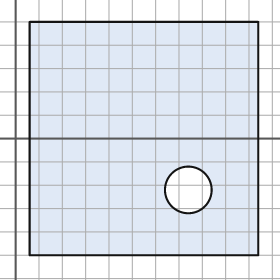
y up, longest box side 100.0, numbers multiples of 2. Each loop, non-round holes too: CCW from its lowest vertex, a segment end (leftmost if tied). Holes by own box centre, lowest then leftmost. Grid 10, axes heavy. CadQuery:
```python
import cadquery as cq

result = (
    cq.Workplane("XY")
    .moveTo(6.0, -50.0)
    .lineTo(104.0, -50.0)
    .lineTo(104.0, 50.0)
    .lineTo(6.0, 50.0)
    .close()
    .moveTo(74.0, -22.0)
    .circle(10.0)
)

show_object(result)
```